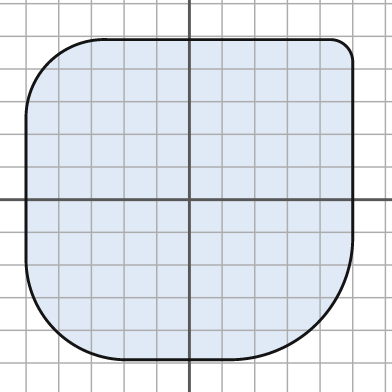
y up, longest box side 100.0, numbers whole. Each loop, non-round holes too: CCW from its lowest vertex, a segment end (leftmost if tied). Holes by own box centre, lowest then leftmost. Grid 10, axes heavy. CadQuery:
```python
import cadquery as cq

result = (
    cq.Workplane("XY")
    .moveTo(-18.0, -49.0)
    .lineTo(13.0, -49.0)
    .threePointArc((39.0, -38.0), (50.0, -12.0))
    .lineTo(50.0, 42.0)
    .threePointArc((48.0, 47.0), (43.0, 49.0))
    .lineTo(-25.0, 49.0)
    .threePointArc((-43.0, 42.0), (-50.0, 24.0))
    .lineTo(-50.0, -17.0)
    .threePointArc((-41.0, -40.0), (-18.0, -49.0))
    .close()
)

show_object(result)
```